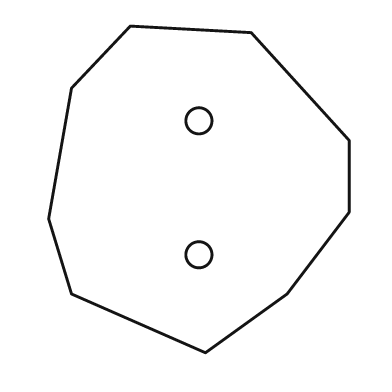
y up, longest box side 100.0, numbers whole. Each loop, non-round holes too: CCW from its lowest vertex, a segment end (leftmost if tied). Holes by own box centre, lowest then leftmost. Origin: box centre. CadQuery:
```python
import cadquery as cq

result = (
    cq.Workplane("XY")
    .moveTo(2.0, -50.0)
    .lineTo(27.0, -32.0)
    .lineTo(46.0, -7.0)
    .lineTo(46.0, 15.0)
    .lineTo(16.0, 48.0)
    .lineTo(-21.0, 50.0)
    .lineTo(-39.0, 31.0)
    .lineTo(-46.0, -9.0)
    .lineTo(-39.0, -32.0)
    .close()
    .moveTo(0.0, -20.0)
    .circle(4.0)
    .moveTo(0.0, 21.0)
    .circle(4.0)
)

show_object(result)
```